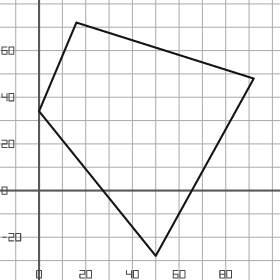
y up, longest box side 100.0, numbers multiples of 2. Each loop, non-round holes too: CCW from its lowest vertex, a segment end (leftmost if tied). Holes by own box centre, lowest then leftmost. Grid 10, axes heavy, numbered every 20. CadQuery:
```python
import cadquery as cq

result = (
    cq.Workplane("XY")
    .moveTo(50.0, -28.0)
    .lineTo(92.0, 48.0)
    .lineTo(16.0, 72.0)
    .lineTo(0.0, 34.0)
    .close()
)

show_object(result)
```